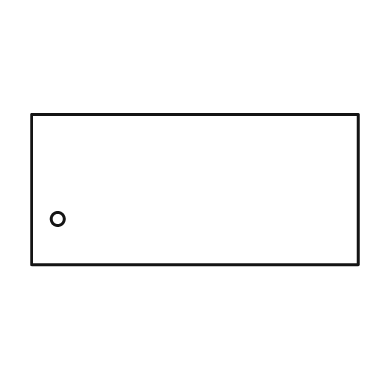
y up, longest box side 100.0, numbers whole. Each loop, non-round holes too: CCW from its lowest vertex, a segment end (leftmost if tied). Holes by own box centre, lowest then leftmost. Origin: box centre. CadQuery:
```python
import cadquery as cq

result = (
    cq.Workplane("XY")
    .moveTo(-50.0, -23.0)
    .lineTo(50.0, -23.0)
    .lineTo(50.0, 23.0)
    .lineTo(-50.0, 23.0)
    .close()
    .moveTo(-42.0, -9.0)
    .circle(2.0)
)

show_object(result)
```